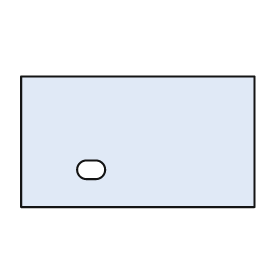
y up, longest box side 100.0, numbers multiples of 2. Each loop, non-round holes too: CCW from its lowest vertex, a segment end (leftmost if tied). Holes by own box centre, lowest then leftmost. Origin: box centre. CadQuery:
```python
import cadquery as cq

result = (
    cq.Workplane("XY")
    .moveTo(-50.0, -28.0)
    .lineTo(50.0, -28.0)
    .lineTo(50.0, 28.0)
    .lineTo(-50.0, 28.0)
    .close()
    .moveTo(-22.0, -16.0)
    .lineTo(-18.0, -16.0)
    .threePointArc((-14.0, -12.0), (-18.0, -8.0))
    .lineTo(-22.0, -8.0)
    .threePointArc((-26.0, -12.0), (-22.0, -16.0))
    .close()
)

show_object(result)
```